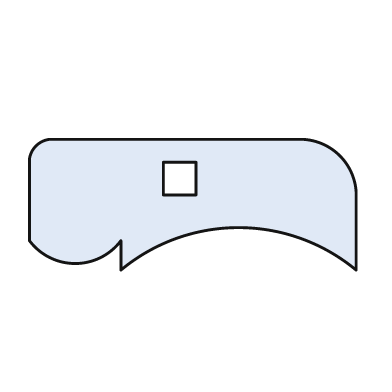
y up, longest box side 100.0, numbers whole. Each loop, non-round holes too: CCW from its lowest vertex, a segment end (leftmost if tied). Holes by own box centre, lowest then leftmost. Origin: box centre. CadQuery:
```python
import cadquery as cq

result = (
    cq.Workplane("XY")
    .moveTo(-22.0, -20.0)
    .threePointArc((14.0, -7.0), (50.0, -20.0))
    .lineTo(50.0, 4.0)
    .threePointArc((45.0, 15.0), (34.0, 20.0))
    .lineTo(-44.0, 20.0)
    .threePointArc((-48.0, 18.0), (-50.0, 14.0))
    .lineTo(-50.0, -11.0)
    .threePointArc((-36.0, -18.0), (-22.0, -11.0))
    .close()
    .moveTo(-9.0, 3.0)
    .lineTo(1.0, 3.0)
    .lineTo(1.0, 13.0)
    .lineTo(-9.0, 13.0)
    .close()
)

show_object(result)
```